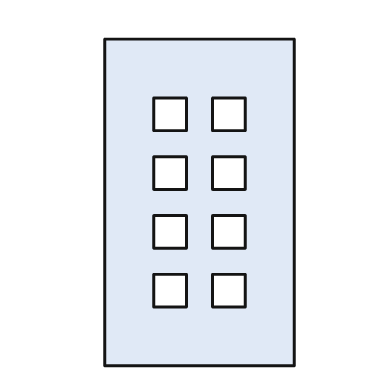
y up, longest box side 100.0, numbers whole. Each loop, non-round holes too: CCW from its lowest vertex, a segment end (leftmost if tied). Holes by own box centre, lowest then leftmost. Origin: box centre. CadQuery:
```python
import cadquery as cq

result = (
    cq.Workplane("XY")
    .moveTo(-29.0, -50.0)
    .lineTo(29.0, -50.0)
    .lineTo(29.0, 50.0)
    .lineTo(-29.0, 50.0)
    .close()
    .moveTo(-14.0, -32.0)
    .lineTo(-4.0, -32.0)
    .lineTo(-4.0, -22.0)
    .lineTo(-14.0, -22.0)
    .close()
    .moveTo(4.0, -32.0)
    .lineTo(14.0, -32.0)
    .lineTo(14.0, -22.0)
    .lineTo(4.0, -22.0)
    .close()
    .moveTo(-14.0, -14.0)
    .lineTo(-4.0, -14.0)
    .lineTo(-4.0, -4.0)
    .lineTo(-14.0, -4.0)
    .close()
    .moveTo(4.0, -14.0)
    .lineTo(14.0, -14.0)
    .lineTo(14.0, -4.0)
    .lineTo(4.0, -4.0)
    .close()
    .moveTo(-14.0, 4.0)
    .lineTo(-4.0, 4.0)
    .lineTo(-4.0, 14.0)
    .lineTo(-14.0, 14.0)
    .close()
    .moveTo(4.0, 4.0)
    .lineTo(14.0, 4.0)
    .lineTo(14.0, 14.0)
    .lineTo(4.0, 14.0)
    .close()
    .moveTo(-14.0, 22.0)
    .lineTo(-4.0, 22.0)
    .lineTo(-4.0, 32.0)
    .lineTo(-14.0, 32.0)
    .close()
    .moveTo(4.0, 22.0)
    .lineTo(14.0, 22.0)
    .lineTo(14.0, 32.0)
    .lineTo(4.0, 32.0)
    .close()
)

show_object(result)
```